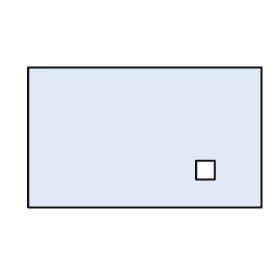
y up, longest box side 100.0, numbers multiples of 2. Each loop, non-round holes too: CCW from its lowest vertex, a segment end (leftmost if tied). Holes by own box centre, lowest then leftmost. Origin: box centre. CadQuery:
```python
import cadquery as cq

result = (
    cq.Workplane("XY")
    .moveTo(-50.0, -30.0)
    .lineTo(50.0, -30.0)
    .lineTo(50.0, 30.0)
    .lineTo(-50.0, 30.0)
    .close()
    .moveTo(22.0, -18.0)
    .lineTo(30.0, -18.0)
    .lineTo(30.0, -10.0)
    .lineTo(22.0, -10.0)
    .close()
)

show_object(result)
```